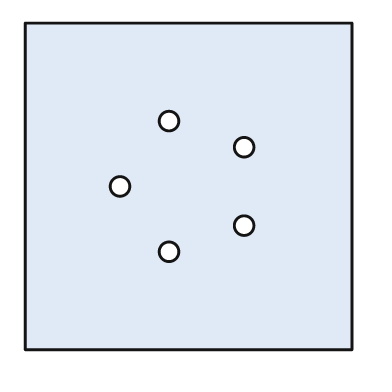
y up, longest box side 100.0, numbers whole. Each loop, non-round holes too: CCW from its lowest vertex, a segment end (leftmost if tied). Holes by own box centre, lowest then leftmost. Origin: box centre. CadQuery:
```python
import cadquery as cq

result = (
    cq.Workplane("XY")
    .moveTo(-50.0, -50.0)
    .lineTo(50.0, -50.0)
    .lineTo(50.0, 50.0)
    .lineTo(-50.0, 50.0)
    .close()
    .moveTo(-6.0, -20.0)
    .circle(3.0)
    .moveTo(17.0, -12.0)
    .circle(3.0)
    .moveTo(-21.0, 0.0)
    .circle(3.0)
    .moveTo(17.0, 12.0)
    .circle(3.0)
    .moveTo(-6.0, 20.0)
    .circle(3.0)
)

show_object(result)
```